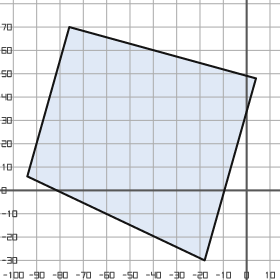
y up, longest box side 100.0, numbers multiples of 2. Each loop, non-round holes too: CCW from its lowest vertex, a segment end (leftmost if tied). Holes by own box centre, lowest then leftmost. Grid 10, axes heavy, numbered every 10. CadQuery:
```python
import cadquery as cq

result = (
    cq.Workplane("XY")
    .moveTo(-18.0, -30.0)
    .lineTo(4.0, 48.0)
    .lineTo(-76.0, 70.0)
    .lineTo(-94.0, 6.0)
    .close()
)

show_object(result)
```